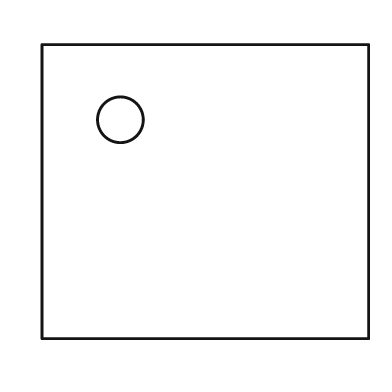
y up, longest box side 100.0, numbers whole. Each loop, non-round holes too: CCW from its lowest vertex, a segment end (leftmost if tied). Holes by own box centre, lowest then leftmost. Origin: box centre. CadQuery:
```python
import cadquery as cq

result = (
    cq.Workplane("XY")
    .moveTo(-50.0, -45.0)
    .lineTo(50.0, -45.0)
    .lineTo(50.0, 45.0)
    .lineTo(-50.0, 45.0)
    .close()
    .moveTo(-26.0, 22.0)
    .circle(7.0)
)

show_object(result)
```